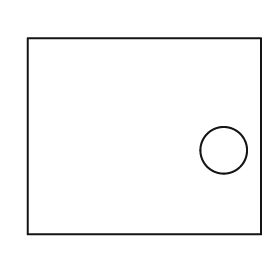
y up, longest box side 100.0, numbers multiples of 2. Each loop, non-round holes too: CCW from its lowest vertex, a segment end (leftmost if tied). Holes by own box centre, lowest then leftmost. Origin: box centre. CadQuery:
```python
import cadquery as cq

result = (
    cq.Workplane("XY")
    .moveTo(-50.0, -42.0)
    .lineTo(50.0, -42.0)
    .lineTo(50.0, 42.0)
    .lineTo(-50.0, 42.0)
    .close()
    .moveTo(34.0, -6.0)
    .circle(10.0)
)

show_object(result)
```